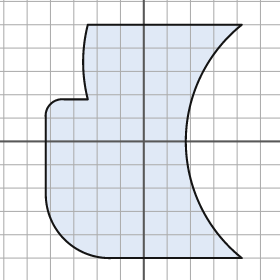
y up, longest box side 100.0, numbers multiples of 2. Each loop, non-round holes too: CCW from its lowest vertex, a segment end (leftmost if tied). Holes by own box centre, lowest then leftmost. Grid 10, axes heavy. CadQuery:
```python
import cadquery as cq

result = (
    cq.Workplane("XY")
    .moveTo(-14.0, -50.0)
    .lineTo(42.0, -50.0)
    .threePointArc((18.0, 0.0), (42.0, 50.0))
    .lineTo(-24.0, 50.0)
    .threePointArc((-26.0, 34.0), (-24.0, 18.0))
    .lineTo(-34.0, 18.0)
    .threePointArc((-40.0, 16.0), (-42.0, 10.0))
    .lineTo(-42.0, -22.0)
    .threePointArc((-34.0, -42.0), (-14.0, -50.0))
    .close()
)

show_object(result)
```